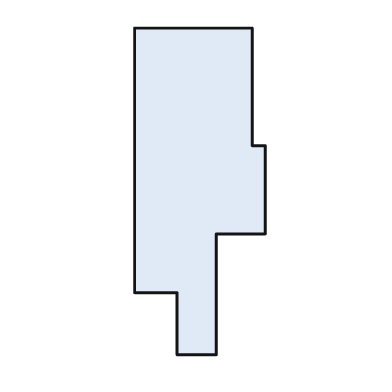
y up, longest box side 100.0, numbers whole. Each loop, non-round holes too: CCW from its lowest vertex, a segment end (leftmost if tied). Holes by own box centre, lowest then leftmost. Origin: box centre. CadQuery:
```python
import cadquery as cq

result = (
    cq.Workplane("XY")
    .moveTo(-7.0, -50.0)
    .lineTo(5.0, -50.0)
    .lineTo(5.0, -13.0)
    .lineTo(20.0, -13.0)
    .lineTo(20.0, 14.0)
    .lineTo(16.0, 14.0)
    .lineTo(16.0, 50.0)
    .lineTo(-20.0, 50.0)
    .lineTo(-20.0, -31.0)
    .lineTo(-7.0, -31.0)
    .close()
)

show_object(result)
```